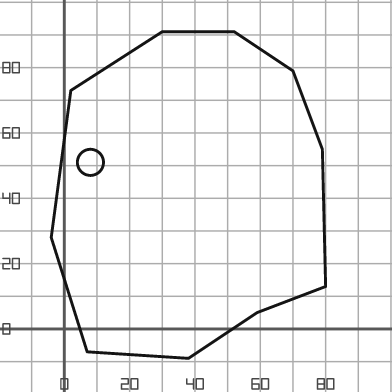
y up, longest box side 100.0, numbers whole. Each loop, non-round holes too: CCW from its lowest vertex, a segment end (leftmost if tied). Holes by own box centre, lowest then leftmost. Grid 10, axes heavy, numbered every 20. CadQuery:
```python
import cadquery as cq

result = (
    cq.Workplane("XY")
    .moveTo(38.0, -9.0)
    .lineTo(59.0, 5.0)
    .lineTo(80.0, 13.0)
    .lineTo(79.0, 55.0)
    .lineTo(70.0, 79.0)
    .lineTo(52.0, 91.0)
    .lineTo(30.0, 91.0)
    .lineTo(2.0, 73.0)
    .lineTo(-4.0, 28.0)
    .lineTo(7.0, -7.0)
    .close()
    .moveTo(8.0, 51.0)
    .circle(4.0)
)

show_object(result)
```